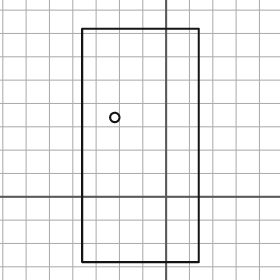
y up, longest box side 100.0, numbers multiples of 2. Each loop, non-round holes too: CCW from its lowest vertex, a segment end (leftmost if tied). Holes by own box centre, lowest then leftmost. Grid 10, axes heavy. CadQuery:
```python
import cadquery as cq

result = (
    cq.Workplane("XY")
    .moveTo(-36.0, -28.0)
    .lineTo(14.0, -28.0)
    .lineTo(14.0, 72.0)
    .lineTo(-36.0, 72.0)
    .close()
    .moveTo(-22.0, 34.0)
    .circle(2.0)
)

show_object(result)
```